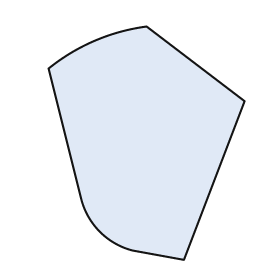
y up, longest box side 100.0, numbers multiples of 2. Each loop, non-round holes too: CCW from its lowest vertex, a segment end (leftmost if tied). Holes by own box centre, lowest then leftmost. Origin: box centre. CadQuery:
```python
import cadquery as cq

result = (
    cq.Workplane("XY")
    .moveTo(16.0, -50.0)
    .lineTo(42.0, 18.0)
    .lineTo(0.0, 50.0)
    .threePointArc((-22.0, 44.0), (-42.0, 32.0))
    .lineTo(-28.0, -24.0)
    .threePointArc((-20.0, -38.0), (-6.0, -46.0))
    .close()
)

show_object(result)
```